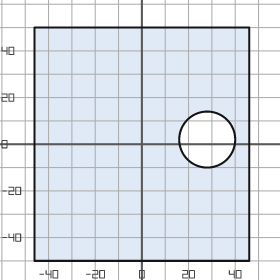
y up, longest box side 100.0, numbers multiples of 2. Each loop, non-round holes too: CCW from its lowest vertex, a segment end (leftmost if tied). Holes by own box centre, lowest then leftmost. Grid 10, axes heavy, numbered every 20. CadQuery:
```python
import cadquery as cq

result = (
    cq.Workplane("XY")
    .moveTo(-46.0, -50.0)
    .lineTo(46.0, -50.0)
    .lineTo(46.0, 50.0)
    .lineTo(-46.0, 50.0)
    .close()
    .moveTo(28.0, 2.0)
    .circle(12.0)
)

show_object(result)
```